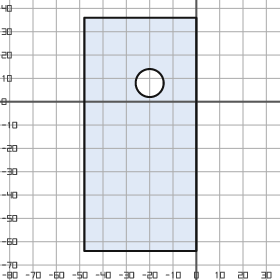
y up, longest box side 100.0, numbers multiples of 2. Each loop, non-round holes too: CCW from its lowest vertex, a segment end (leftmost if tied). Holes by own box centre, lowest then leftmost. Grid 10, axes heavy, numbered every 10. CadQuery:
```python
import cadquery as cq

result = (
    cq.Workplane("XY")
    .moveTo(-48.0, -64.0)
    .lineTo(0.0, -64.0)
    .lineTo(0.0, 36.0)
    .lineTo(-48.0, 36.0)
    .close()
    .moveTo(-20.0, 8.0)
    .circle(6.0)
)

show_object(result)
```